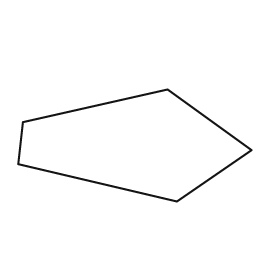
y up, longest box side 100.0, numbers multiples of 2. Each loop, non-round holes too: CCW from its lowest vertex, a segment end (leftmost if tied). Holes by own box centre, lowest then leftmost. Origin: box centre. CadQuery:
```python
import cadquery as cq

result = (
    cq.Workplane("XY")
    .moveTo(18.0, -24.0)
    .lineTo(50.0, -2.0)
    .lineTo(14.0, 24.0)
    .lineTo(-48.0, 10.0)
    .lineTo(-50.0, -8.0)
    .close()
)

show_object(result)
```